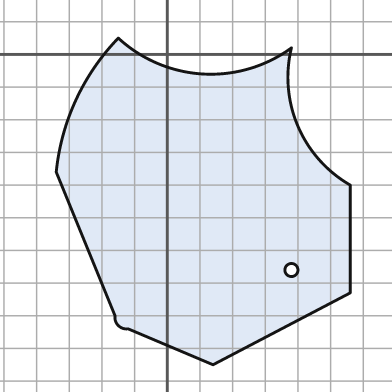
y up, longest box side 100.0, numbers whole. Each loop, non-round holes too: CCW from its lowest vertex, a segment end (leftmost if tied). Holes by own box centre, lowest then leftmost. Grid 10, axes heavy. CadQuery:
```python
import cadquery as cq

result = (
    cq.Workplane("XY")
    .moveTo(14.0, -95.0)
    .lineTo(56.0, -73.0)
    .lineTo(56.0, -40.0)
    .threePointArc((40.0, -22.0), (38.0, 2.0))
    .threePointArc((11.0, -6.0), (-15.0, 5.0))
    .threePointArc((-28.0, -14.0), (-34.0, -36.0))
    .lineTo(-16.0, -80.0)
    .threePointArc((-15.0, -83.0), (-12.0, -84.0))
    .close()
    .moveTo(38.0, -66.0)
    .circle(2.0)
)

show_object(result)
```